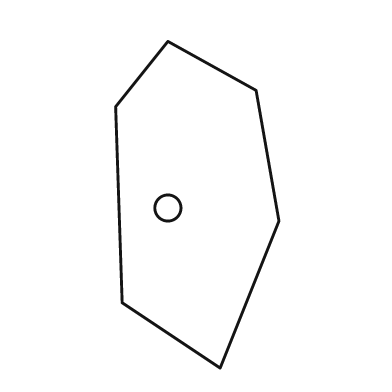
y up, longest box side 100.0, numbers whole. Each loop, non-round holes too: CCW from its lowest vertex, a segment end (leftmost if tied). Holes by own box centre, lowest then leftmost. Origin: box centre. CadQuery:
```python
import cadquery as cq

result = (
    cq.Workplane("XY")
    .moveTo(7.0, -50.0)
    .lineTo(25.0, -5.0)
    .lineTo(18.0, 35.0)
    .lineTo(-9.0, 50.0)
    .lineTo(-25.0, 30.0)
    .lineTo(-23.0, -30.0)
    .close()
    .moveTo(-9.0, -1.0)
    .circle(4.0)
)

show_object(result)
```